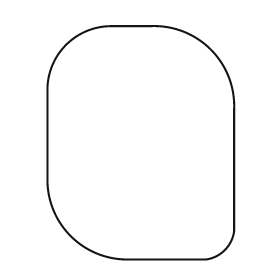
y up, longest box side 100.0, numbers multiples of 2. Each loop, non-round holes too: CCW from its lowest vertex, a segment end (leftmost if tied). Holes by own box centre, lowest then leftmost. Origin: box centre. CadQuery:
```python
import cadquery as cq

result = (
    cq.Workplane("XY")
    .moveTo(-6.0, -50.0)
    .lineTo(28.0, -50.0)
    .threePointArc((36.0, -46.0), (40.0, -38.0))
    .lineTo(40.0, 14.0)
    .threePointArc((30.0, 40.0), (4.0, 50.0))
    .lineTo(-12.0, 50.0)
    .threePointArc((-32.0, 42.0), (-40.0, 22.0))
    .lineTo(-40.0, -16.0)
    .threePointArc((-30.0, -40.0), (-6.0, -50.0))
    .close()
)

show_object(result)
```